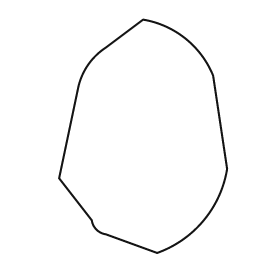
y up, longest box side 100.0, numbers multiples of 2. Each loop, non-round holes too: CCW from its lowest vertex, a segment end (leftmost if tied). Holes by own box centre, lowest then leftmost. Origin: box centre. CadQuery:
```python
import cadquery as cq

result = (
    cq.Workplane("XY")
    .moveTo(6.0, -50.0)
    .threePointArc((26.0, -36.0), (36.0, -14.0))
    .lineTo(30.0, 26.0)
    .threePointArc((18.0, 42.0), (0.0, 50.0))
    .lineTo(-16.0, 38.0)
    .threePointArc((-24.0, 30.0), (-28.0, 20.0))
    .lineTo(-36.0, -18.0)
    .lineTo(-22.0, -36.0)
    .threePointArc((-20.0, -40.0), (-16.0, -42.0))
    .close()
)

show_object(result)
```